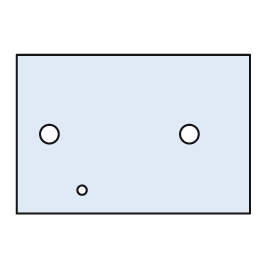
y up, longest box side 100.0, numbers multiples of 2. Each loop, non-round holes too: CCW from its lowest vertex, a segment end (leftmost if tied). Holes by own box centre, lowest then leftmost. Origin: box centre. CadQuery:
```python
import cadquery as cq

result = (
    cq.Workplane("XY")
    .moveTo(-50.0, -34.0)
    .lineTo(50.0, -34.0)
    .lineTo(50.0, 34.0)
    .lineTo(-50.0, 34.0)
    .close()
    .moveTo(-22.0, -24.0)
    .circle(2.0)
    .moveTo(-36.0, 0.0)
    .circle(4.0)
    .moveTo(24.0, 0.0)
    .circle(4.0)
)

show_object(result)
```